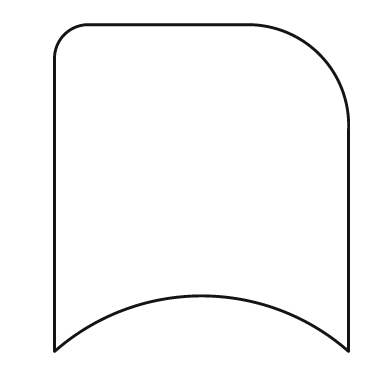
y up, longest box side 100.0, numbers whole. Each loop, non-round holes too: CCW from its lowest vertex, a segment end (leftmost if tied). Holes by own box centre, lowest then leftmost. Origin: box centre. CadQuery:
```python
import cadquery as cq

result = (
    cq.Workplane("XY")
    .moveTo(-45.0, -50.0)
    .threePointArc((0.0, -33.0), (45.0, -50.0))
    .lineTo(45.0, 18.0)
    .threePointArc((36.0, 41.0), (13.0, 50.0))
    .lineTo(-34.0, 50.0)
    .threePointArc((-42.0, 47.0), (-45.0, 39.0))
    .close()
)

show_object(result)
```